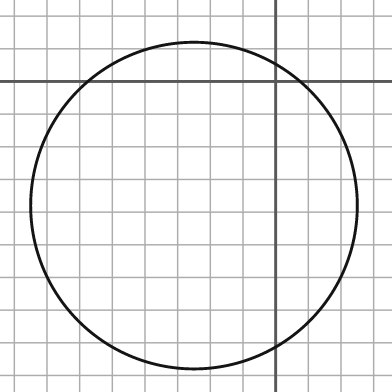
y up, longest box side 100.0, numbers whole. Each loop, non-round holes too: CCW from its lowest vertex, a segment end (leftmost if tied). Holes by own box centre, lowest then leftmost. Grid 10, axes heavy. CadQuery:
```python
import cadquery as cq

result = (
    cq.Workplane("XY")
    .moveTo(-25.0, -38.0)
    .circle(50.0)
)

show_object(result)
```